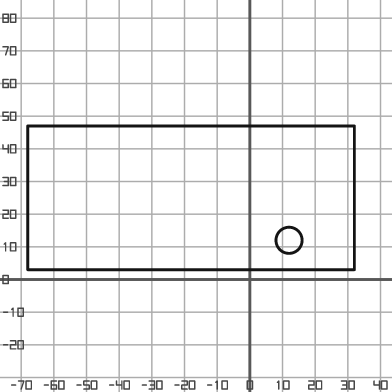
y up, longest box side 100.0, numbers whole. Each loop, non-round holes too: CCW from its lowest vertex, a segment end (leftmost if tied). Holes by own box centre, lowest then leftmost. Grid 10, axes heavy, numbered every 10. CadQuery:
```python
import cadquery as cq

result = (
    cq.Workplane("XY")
    .moveTo(-68.0, 3.0)
    .lineTo(32.0, 3.0)
    .lineTo(32.0, 47.0)
    .lineTo(-68.0, 47.0)
    .close()
    .moveTo(12.0, 12.0)
    .circle(4.0)
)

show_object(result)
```